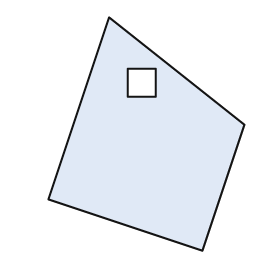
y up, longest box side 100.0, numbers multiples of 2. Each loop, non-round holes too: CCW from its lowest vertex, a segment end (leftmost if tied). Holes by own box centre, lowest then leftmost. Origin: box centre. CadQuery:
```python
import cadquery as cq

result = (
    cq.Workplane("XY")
    .moveTo(24.0, -50.0)
    .lineTo(42.0, 4.0)
    .lineTo(-16.0, 50.0)
    .lineTo(-42.0, -28.0)
    .close()
    .moveTo(-8.0, 16.0)
    .lineTo(4.0, 16.0)
    .lineTo(4.0, 28.0)
    .lineTo(-8.0, 28.0)
    .close()
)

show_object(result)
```